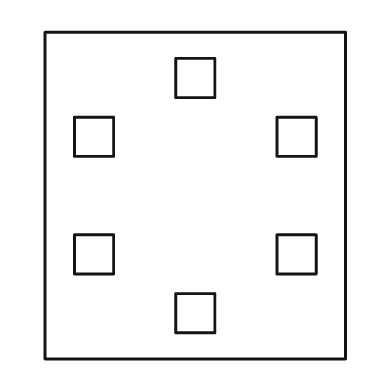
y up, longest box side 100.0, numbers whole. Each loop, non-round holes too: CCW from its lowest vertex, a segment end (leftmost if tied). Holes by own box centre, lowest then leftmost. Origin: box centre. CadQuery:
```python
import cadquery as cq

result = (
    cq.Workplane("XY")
    .moveTo(-46.0, -50.0)
    .lineTo(46.0, -50.0)
    .lineTo(46.0, 50.0)
    .lineTo(-46.0, 50.0)
    .close()
    .moveTo(-6.0, -42.0)
    .lineTo(6.0, -42.0)
    .lineTo(6.0, -30.0)
    .lineTo(-6.0, -30.0)
    .close()
    .moveTo(-37.0, -24.0)
    .lineTo(-25.0, -24.0)
    .lineTo(-25.0, -12.0)
    .lineTo(-37.0, -12.0)
    .close()
    .moveTo(25.0, -24.0)
    .lineTo(37.0, -24.0)
    .lineTo(37.0, -12.0)
    .lineTo(25.0, -12.0)
    .close()
    .moveTo(-37.0, 12.0)
    .lineTo(-25.0, 12.0)
    .lineTo(-25.0, 24.0)
    .lineTo(-37.0, 24.0)
    .close()
    .moveTo(25.0, 12.0)
    .lineTo(37.0, 12.0)
    .lineTo(37.0, 24.0)
    .lineTo(25.0, 24.0)
    .close()
    .moveTo(-6.0, 30.0)
    .lineTo(6.0, 30.0)
    .lineTo(6.0, 42.0)
    .lineTo(-6.0, 42.0)
    .close()
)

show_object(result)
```